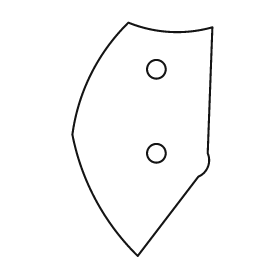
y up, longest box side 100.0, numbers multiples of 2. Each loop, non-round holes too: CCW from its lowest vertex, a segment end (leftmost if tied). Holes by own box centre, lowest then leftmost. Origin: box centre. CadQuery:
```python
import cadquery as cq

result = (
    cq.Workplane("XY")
    .moveTo(-2.0, -50.0)
    .lineTo(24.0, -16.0)
    .threePointArc((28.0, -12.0), (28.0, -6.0))
    .lineTo(30.0, 48.0)
    .threePointArc((12.0, 46.0), (-6.0, 50.0))
    .threePointArc((-22.0, 28.0), (-30.0, 2.0))
    .threePointArc((-20.0, -26.0), (-2.0, -50.0))
    .close()
    .moveTo(6.0, -6.0)
    .circle(4.0)
    .moveTo(6.0, 30.0)
    .circle(4.0)
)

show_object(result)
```